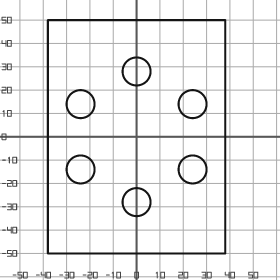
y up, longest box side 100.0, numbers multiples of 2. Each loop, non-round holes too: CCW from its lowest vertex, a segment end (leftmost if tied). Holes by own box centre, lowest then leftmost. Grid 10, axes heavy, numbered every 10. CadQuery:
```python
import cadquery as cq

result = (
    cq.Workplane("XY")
    .moveTo(-38.0, -50.0)
    .lineTo(38.0, -50.0)
    .lineTo(38.0, 50.0)
    .lineTo(-38.0, 50.0)
    .close()
    .moveTo(0.0, -28.0)
    .circle(6.0)
    .moveTo(-24.0, -14.0)
    .circle(6.0)
    .moveTo(24.0, -14.0)
    .circle(6.0)
    .moveTo(-24.0, 14.0)
    .circle(6.0)
    .moveTo(24.0, 14.0)
    .circle(6.0)
    .moveTo(0.0, 28.0)
    .circle(6.0)
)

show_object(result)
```